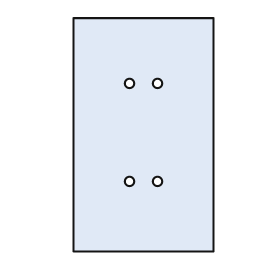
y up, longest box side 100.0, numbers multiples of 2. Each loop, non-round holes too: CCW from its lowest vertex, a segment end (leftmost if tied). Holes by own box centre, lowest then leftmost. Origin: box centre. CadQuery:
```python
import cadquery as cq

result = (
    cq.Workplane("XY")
    .moveTo(-30.0, -50.0)
    .lineTo(30.0, -50.0)
    .lineTo(30.0, 50.0)
    .lineTo(-30.0, 50.0)
    .close()
    .moveTo(-6.0, -20.0)
    .circle(2.0)
    .moveTo(6.0, -20.0)
    .circle(2.0)
    .moveTo(-6.0, 22.0)
    .circle(2.0)
    .moveTo(6.0, 22.0)
    .circle(2.0)
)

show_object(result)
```